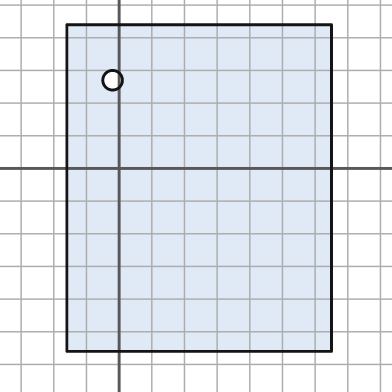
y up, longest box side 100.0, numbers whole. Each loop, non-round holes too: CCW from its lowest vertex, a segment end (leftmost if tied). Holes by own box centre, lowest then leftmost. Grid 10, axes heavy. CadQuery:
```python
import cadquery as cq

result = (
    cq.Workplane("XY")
    .moveTo(-16.0, -56.0)
    .lineTo(65.0, -56.0)
    .lineTo(65.0, 44.0)
    .lineTo(-16.0, 44.0)
    .close()
    .moveTo(-2.0, 27.0)
    .circle(3.0)
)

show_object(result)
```